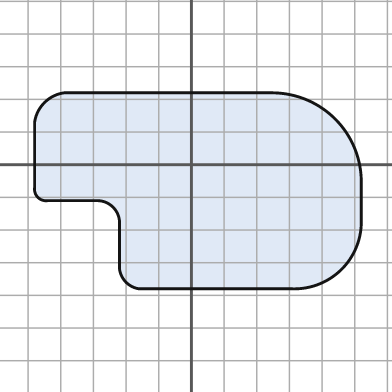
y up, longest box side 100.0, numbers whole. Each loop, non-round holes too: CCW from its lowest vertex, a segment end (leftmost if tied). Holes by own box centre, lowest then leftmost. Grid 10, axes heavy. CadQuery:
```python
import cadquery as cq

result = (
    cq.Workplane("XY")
    .moveTo(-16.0, -38.0)
    .lineTo(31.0, -38.0)
    .threePointArc((46.0, -32.0), (52.0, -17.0))
    .lineTo(52.0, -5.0)
    .threePointArc((44.0, 14.0), (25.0, 22.0))
    .lineTo(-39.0, 22.0)
    .threePointArc((-45.0, 19.0), (-48.0, 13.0))
    .lineTo(-48.0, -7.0)
    .threePointArc((-47.0, -10.0), (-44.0, -11.0))
    .lineTo(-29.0, -11.0)
    .threePointArc((-24.0, -13.0), (-22.0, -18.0))
    .lineTo(-22.0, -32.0)
    .threePointArc((-20.0, -36.0), (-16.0, -38.0))
    .close()
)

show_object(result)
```